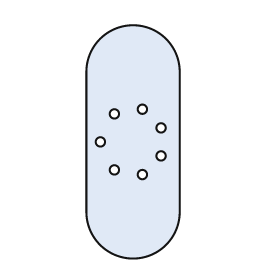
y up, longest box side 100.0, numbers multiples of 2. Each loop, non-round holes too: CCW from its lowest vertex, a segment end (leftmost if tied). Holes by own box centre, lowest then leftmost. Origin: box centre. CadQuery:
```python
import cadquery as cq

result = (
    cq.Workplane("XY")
    .moveTo(-20.0, -30.0)
    .threePointArc((0.0, -50.0), (20.0, -30.0))
    .lineTo(20.0, 30.0)
    .threePointArc((0.0, 50.0), (-20.0, 30.0))
    .close()
    .moveTo(4.0, -14.0)
    .circle(2.0)
    .moveTo(-8.0, -12.0)
    .circle(2.0)
    .moveTo(12.0, -6.0)
    .circle(2.0)
    .moveTo(-14.0, 0.0)
    .circle(2.0)
    .moveTo(12.0, 6.0)
    .circle(2.0)
    .moveTo(-8.0, 12.0)
    .circle(2.0)
    .moveTo(4.0, 14.0)
    .circle(2.0)
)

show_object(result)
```